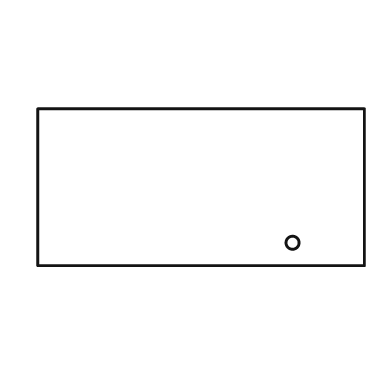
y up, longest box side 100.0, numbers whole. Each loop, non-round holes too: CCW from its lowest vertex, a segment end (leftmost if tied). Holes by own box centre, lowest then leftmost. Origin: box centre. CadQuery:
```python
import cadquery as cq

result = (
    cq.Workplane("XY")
    .moveTo(-50.0, -24.0)
    .lineTo(50.0, -24.0)
    .lineTo(50.0, 24.0)
    .lineTo(-50.0, 24.0)
    .close()
    .moveTo(28.0, -17.0)
    .circle(2.0)
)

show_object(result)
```